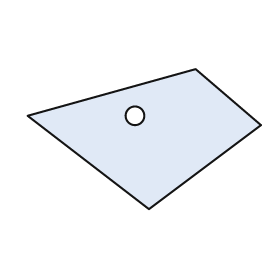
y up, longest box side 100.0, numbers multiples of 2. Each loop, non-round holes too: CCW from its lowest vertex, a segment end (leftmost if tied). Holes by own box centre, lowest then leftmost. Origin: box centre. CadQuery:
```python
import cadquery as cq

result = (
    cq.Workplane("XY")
    .moveTo(2.0, -30.0)
    .lineTo(50.0, 6.0)
    .lineTo(22.0, 30.0)
    .lineTo(-50.0, 10.0)
    .close()
    .moveTo(-4.0, 10.0)
    .circle(4.0)
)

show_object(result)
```